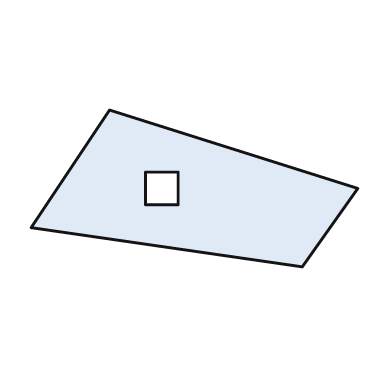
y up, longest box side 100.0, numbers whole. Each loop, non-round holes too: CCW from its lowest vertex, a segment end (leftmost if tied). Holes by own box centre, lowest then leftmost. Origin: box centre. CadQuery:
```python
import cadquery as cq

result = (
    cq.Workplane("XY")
    .moveTo(33.0, -24.0)
    .lineTo(50.0, 0.0)
    .lineTo(-26.0, 24.0)
    .lineTo(-50.0, -12.0)
    .close()
    .moveTo(-15.0, -5.0)
    .lineTo(-5.0, -5.0)
    .lineTo(-5.0, 5.0)
    .lineTo(-15.0, 5.0)
    .close()
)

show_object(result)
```